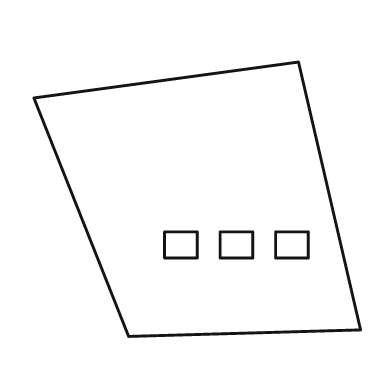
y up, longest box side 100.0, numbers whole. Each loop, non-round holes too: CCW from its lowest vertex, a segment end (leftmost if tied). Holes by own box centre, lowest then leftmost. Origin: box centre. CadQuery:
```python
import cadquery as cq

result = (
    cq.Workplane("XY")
    .moveTo(-21.0, -42.0)
    .lineTo(50.0, -40.0)
    .lineTo(31.0, 42.0)
    .lineTo(-50.0, 31.0)
    .close()
    .moveTo(-10.0, -18.0)
    .lineTo(0.0, -18.0)
    .lineTo(0.0, -10.0)
    .lineTo(-10.0, -10.0)
    .close()
    .moveTo(7.0, -18.0)
    .lineTo(17.0, -18.0)
    .lineTo(17.0, -10.0)
    .lineTo(7.0, -10.0)
    .close()
    .moveTo(24.0, -18.0)
    .lineTo(34.0, -18.0)
    .lineTo(34.0, -10.0)
    .lineTo(24.0, -10.0)
    .close()
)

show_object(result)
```